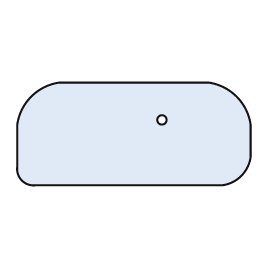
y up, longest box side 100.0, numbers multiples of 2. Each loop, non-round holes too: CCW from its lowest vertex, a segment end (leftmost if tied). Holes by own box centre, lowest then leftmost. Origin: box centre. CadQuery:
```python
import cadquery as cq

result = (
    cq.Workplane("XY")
    .moveTo(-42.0, -22.0)
    .lineTo(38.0, -22.0)
    .threePointArc((46.0, -18.0), (50.0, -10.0))
    .lineTo(50.0, 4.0)
    .threePointArc((44.0, 16.0), (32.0, 22.0))
    .lineTo(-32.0, 22.0)
    .threePointArc((-44.0, 16.0), (-50.0, 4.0))
    .lineTo(-50.0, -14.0)
    .threePointArc((-48.0, -20.0), (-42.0, -22.0))
    .close()
    .moveTo(12.0, 6.0)
    .circle(2.0)
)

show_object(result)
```